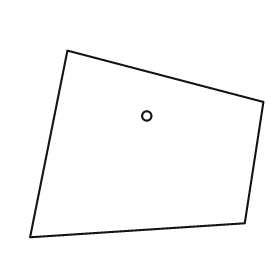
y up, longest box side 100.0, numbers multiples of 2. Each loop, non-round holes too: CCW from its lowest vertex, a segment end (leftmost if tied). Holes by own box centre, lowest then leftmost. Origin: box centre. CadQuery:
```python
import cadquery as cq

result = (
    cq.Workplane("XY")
    .moveTo(-50.0, -40.0)
    .lineTo(42.0, -34.0)
    .lineTo(50.0, 18.0)
    .lineTo(-34.0, 40.0)
    .close()
    .moveTo(0.0, 12.0)
    .circle(2.0)
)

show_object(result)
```